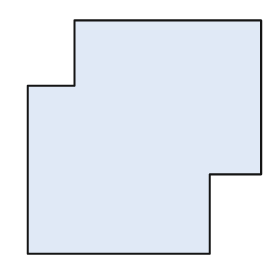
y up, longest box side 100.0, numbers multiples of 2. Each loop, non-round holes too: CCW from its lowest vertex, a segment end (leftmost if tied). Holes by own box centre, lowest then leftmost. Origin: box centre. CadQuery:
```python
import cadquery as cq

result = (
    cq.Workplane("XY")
    .moveTo(-50.0, -50.0)
    .lineTo(28.0, -50.0)
    .lineTo(28.0, -16.0)
    .lineTo(50.0, -16.0)
    .lineTo(50.0, 50.0)
    .lineTo(-30.0, 50.0)
    .lineTo(-30.0, 22.0)
    .lineTo(-50.0, 22.0)
    .close()
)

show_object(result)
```